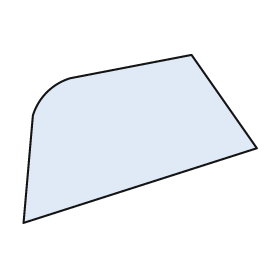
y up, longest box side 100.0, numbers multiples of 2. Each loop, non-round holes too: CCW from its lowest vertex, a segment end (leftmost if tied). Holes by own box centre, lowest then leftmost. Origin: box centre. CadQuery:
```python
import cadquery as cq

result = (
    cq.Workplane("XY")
    .moveTo(-50.0, -36.0)
    .lineTo(50.0, -4.0)
    .lineTo(22.0, 36.0)
    .lineTo(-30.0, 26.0)
    .threePointArc((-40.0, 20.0), (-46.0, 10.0))
    .close()
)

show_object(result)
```